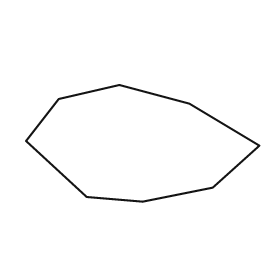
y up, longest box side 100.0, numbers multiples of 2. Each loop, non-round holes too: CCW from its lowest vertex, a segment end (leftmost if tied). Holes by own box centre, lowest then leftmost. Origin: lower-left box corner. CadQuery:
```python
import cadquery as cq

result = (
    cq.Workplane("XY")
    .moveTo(50.0, 0.0)
    .lineTo(80.0, 6.0)
    .lineTo(100.0, 24.0)
    .lineTo(70.0, 42.0)
    .lineTo(40.0, 50.0)
    .lineTo(14.0, 44.0)
    .lineTo(0.0, 26.0)
    .lineTo(26.0, 2.0)
    .close()
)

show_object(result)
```